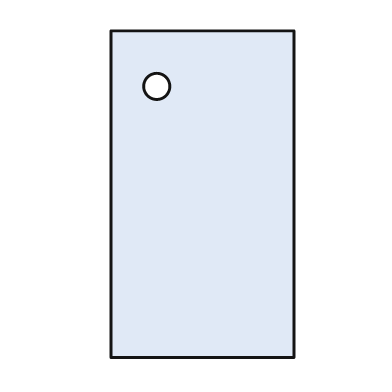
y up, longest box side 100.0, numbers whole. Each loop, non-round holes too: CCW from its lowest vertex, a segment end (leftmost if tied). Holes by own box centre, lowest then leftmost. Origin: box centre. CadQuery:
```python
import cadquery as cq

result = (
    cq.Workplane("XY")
    .moveTo(-28.0, -50.0)
    .lineTo(28.0, -50.0)
    .lineTo(28.0, 50.0)
    .lineTo(-28.0, 50.0)
    .close()
    .moveTo(-14.0, 33.0)
    .circle(4.0)
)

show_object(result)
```